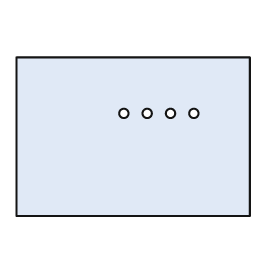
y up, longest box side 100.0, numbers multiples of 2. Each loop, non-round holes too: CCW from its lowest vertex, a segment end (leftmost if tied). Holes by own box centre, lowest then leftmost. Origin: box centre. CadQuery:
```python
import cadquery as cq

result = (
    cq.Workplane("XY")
    .moveTo(-50.0, -34.0)
    .lineTo(50.0, -34.0)
    .lineTo(50.0, 34.0)
    .lineTo(-50.0, 34.0)
    .close()
    .moveTo(-4.0, 10.0)
    .circle(2.0)
    .moveTo(6.0, 10.0)
    .circle(2.0)
    .moveTo(16.0, 10.0)
    .circle(2.0)
    .moveTo(26.0, 10.0)
    .circle(2.0)
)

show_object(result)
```